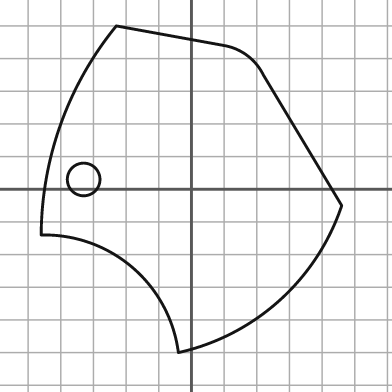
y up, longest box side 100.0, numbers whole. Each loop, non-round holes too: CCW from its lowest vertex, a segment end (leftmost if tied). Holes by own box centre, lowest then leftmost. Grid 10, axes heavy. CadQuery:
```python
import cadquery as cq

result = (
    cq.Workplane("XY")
    .moveTo(-4.0, -50.0)
    .threePointArc((27.0, -34.0), (46.0, -5.0))
    .lineTo(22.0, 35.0)
    .threePointArc((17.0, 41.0), (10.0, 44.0))
    .lineTo(-23.0, 50.0)
    .threePointArc((-40.0, 20.0), (-46.0, -14.0))
    .threePointArc((-18.0, -24.0), (-4.0, -50.0))
    .close()
    .moveTo(-33.0, 3.0)
    .circle(5.0)
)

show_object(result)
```